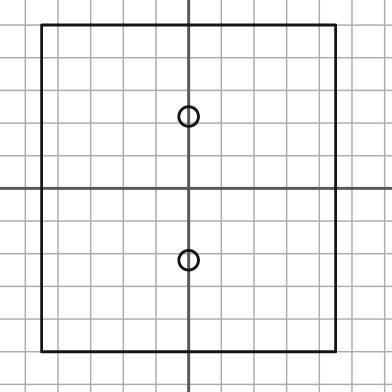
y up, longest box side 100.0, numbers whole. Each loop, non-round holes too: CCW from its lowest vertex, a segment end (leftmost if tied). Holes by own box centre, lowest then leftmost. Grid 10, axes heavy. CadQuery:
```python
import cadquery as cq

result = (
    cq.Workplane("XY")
    .moveTo(-45.0, -50.0)
    .lineTo(45.0, -50.0)
    .lineTo(45.0, 50.0)
    .lineTo(-45.0, 50.0)
    .close()
    .moveTo(0.0, -22.0)
    .circle(3.0)
    .moveTo(0.0, 22.0)
    .circle(3.0)
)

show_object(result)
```